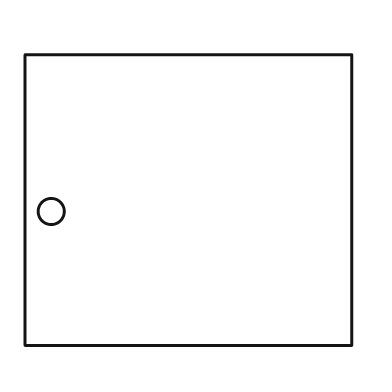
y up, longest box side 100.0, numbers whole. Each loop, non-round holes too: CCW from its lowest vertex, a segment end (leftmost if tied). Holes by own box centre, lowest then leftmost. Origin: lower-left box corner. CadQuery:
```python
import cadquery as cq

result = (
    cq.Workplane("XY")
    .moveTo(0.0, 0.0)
    .lineTo(100.0, 0.0)
    .lineTo(100.0, 89.0)
    .lineTo(0.0, 89.0)
    .close()
    .moveTo(8.0, 41.0)
    .circle(4.0)
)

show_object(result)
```